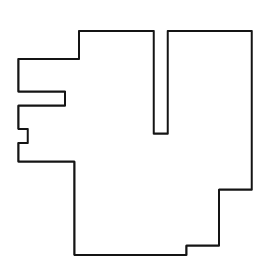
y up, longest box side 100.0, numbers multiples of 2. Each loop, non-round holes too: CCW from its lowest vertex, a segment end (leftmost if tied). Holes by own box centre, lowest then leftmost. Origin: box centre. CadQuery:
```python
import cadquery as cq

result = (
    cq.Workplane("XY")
    .moveTo(-26.0, -48.0)
    .lineTo(22.0, -48.0)
    .lineTo(22.0, -44.0)
    .lineTo(36.0, -44.0)
    .lineTo(36.0, -20.0)
    .lineTo(50.0, -20.0)
    .lineTo(50.0, 48.0)
    .lineTo(14.0, 48.0)
    .lineTo(14.0, 4.0)
    .lineTo(8.0, 4.0)
    .lineTo(8.0, 48.0)
    .lineTo(-24.0, 48.0)
    .lineTo(-24.0, 36.0)
    .lineTo(-50.0, 36.0)
    .lineTo(-50.0, 22.0)
    .lineTo(-30.0, 22.0)
    .lineTo(-30.0, 16.0)
    .lineTo(-50.0, 16.0)
    .lineTo(-50.0, 6.0)
    .lineTo(-46.0, 6.0)
    .lineTo(-46.0, 0.0)
    .lineTo(-50.0, 0.0)
    .lineTo(-50.0, -8.0)
    .lineTo(-26.0, -8.0)
    .close()
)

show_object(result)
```